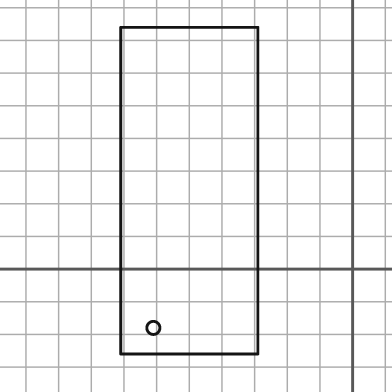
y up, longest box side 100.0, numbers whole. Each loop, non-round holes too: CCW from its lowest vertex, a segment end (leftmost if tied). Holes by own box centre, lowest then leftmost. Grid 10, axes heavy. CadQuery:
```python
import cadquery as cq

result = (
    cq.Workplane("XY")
    .moveTo(-71.0, -26.0)
    .lineTo(-29.0, -26.0)
    .lineTo(-29.0, 74.0)
    .lineTo(-71.0, 74.0)
    .close()
    .moveTo(-61.0, -18.0)
    .circle(2.0)
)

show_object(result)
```